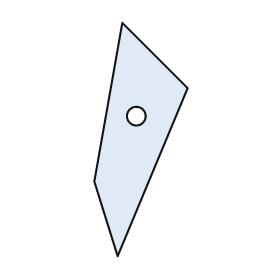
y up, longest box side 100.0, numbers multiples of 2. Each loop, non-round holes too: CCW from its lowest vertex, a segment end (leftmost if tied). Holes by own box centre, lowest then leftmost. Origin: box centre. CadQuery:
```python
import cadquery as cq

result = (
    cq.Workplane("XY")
    .moveTo(-10.0, -50.0)
    .lineTo(20.0, 22.0)
    .lineTo(-8.0, 50.0)
    .lineTo(-20.0, -18.0)
    .close()
    .moveTo(-2.0, 10.0)
    .circle(4.0)
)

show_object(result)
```